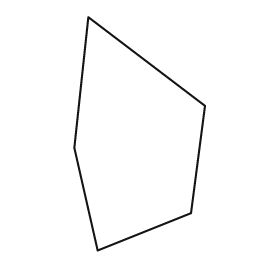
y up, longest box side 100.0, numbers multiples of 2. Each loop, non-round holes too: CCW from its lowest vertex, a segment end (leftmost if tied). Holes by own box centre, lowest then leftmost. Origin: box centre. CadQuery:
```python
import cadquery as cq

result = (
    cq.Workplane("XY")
    .moveTo(-18.0, -50.0)
    .lineTo(22.0, -34.0)
    .lineTo(28.0, 12.0)
    .lineTo(-22.0, 50.0)
    .lineTo(-28.0, -6.0)
    .close()
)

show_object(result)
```